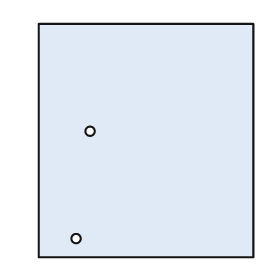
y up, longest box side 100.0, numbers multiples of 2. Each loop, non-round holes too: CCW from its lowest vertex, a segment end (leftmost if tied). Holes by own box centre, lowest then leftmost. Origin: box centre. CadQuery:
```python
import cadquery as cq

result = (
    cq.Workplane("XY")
    .moveTo(-46.0, -50.0)
    .lineTo(46.0, -50.0)
    .lineTo(46.0, 50.0)
    .lineTo(-46.0, 50.0)
    .close()
    .moveTo(-30.0, -42.0)
    .circle(2.0)
    .moveTo(-24.0, 4.0)
    .circle(2.0)
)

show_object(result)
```